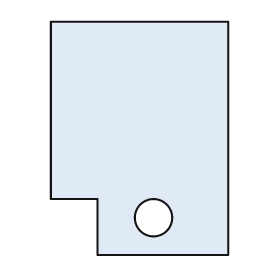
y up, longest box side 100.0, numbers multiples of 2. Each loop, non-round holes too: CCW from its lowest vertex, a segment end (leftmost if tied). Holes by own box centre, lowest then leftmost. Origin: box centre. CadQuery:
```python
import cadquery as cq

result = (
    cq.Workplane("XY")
    .moveTo(-18.0, -50.0)
    .lineTo(38.0, -50.0)
    .lineTo(38.0, 50.0)
    .lineTo(-38.0, 50.0)
    .lineTo(-38.0, -26.0)
    .lineTo(-18.0, -26.0)
    .close()
    .moveTo(6.0, -34.0)
    .circle(8.0)
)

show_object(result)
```